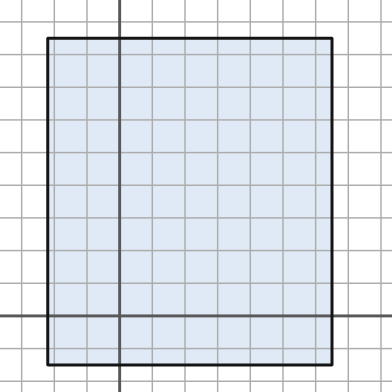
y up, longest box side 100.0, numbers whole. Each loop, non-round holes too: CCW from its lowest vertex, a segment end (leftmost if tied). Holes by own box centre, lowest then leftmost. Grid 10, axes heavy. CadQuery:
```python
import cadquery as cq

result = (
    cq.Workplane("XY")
    .moveTo(-22.0, -15.0)
    .lineTo(65.0, -15.0)
    .lineTo(65.0, 85.0)
    .lineTo(-22.0, 85.0)
    .close()
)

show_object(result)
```